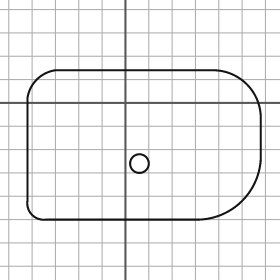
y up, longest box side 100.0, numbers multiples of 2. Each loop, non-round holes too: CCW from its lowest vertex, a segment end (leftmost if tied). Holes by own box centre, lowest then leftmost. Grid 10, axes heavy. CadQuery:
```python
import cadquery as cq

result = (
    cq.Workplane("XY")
    .moveTo(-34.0, -50.0)
    .lineTo(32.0, -50.0)
    .threePointArc((50.0, -42.0), (58.0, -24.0))
    .lineTo(58.0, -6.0)
    .threePointArc((52.0, 8.0), (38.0, 14.0))
    .lineTo(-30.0, 14.0)
    .threePointArc((-38.0, 10.0), (-42.0, 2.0))
    .lineTo(-42.0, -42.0)
    .threePointArc((-40.0, -48.0), (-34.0, -50.0))
    .close()
    .moveTo(6.0, -26.0)
    .circle(4.0)
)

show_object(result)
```